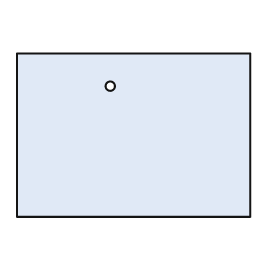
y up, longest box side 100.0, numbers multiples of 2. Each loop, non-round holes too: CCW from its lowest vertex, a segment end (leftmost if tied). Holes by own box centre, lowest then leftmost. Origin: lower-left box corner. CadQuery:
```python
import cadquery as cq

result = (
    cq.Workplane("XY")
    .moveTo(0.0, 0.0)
    .lineTo(100.0, 0.0)
    .lineTo(100.0, 70.0)
    .lineTo(0.0, 70.0)
    .close()
    .moveTo(40.0, 56.0)
    .circle(2.0)
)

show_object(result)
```